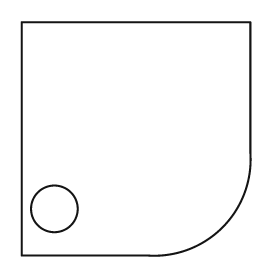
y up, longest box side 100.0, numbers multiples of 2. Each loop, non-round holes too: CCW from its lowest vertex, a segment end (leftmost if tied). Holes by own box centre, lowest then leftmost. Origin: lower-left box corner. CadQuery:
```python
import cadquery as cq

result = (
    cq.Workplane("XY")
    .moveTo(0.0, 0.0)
    .lineTo(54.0, 0.0)
    .threePointArc((86.0, 12.0), (98.0, 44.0))
    .lineTo(98.0, 100.0)
    .lineTo(0.0, 100.0)
    .close()
    .moveTo(14.0, 20.0)
    .circle(10.0)
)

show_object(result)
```